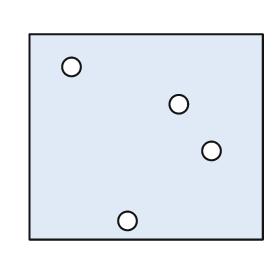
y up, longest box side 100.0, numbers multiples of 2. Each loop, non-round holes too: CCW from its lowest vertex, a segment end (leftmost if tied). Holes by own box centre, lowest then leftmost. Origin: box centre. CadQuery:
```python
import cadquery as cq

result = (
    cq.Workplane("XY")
    .moveTo(-50.0, -44.0)
    .lineTo(50.0, -44.0)
    .lineTo(50.0, 44.0)
    .lineTo(-50.0, 44.0)
    .close()
    .moveTo(-8.0, -36.0)
    .circle(4.0)
    .moveTo(28.0, -6.0)
    .circle(4.0)
    .moveTo(14.0, 14.0)
    .circle(4.0)
    .moveTo(-32.0, 30.0)
    .circle(4.0)
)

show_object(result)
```